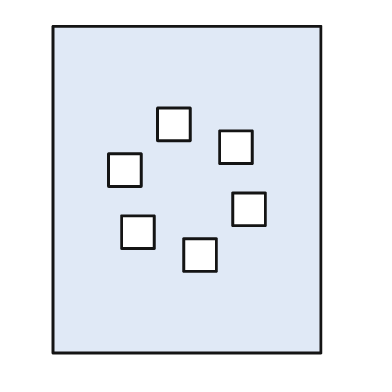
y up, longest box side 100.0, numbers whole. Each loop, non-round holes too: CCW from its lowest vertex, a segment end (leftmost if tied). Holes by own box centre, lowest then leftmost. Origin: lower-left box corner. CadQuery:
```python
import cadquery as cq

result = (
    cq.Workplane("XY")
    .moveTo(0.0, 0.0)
    .lineTo(82.0, 0.0)
    .lineTo(82.0, 100.0)
    .lineTo(0.0, 100.0)
    .close()
    .moveTo(40.0, 25.0)
    .lineTo(50.0, 25.0)
    .lineTo(50.0, 35.0)
    .lineTo(40.0, 35.0)
    .close()
    .moveTo(21.0, 32.0)
    .lineTo(31.0, 32.0)
    .lineTo(31.0, 42.0)
    .lineTo(21.0, 42.0)
    .close()
    .moveTo(55.0, 39.0)
    .lineTo(65.0, 39.0)
    .lineTo(65.0, 49.0)
    .lineTo(55.0, 49.0)
    .close()
    .moveTo(17.0, 51.0)
    .lineTo(27.0, 51.0)
    .lineTo(27.0, 61.0)
    .lineTo(17.0, 61.0)
    .close()
    .moveTo(51.0, 58.0)
    .lineTo(61.0, 58.0)
    .lineTo(61.0, 68.0)
    .lineTo(51.0, 68.0)
    .close()
    .moveTo(32.0, 65.0)
    .lineTo(42.0, 65.0)
    .lineTo(42.0, 75.0)
    .lineTo(32.0, 75.0)
    .close()
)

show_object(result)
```